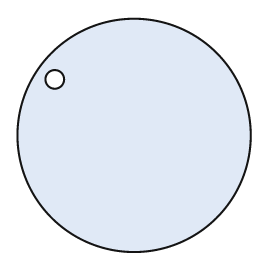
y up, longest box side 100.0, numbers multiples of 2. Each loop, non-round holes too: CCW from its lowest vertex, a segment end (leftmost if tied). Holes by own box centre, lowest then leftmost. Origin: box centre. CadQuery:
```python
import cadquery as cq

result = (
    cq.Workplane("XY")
    .moveTo(0.0, 0.0)
    .circle(50.0)
    .moveTo(-34.0, 24.0)
    .circle(4.0)
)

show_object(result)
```